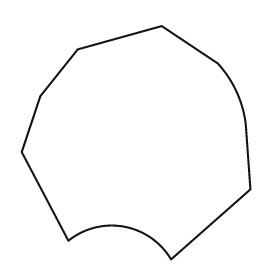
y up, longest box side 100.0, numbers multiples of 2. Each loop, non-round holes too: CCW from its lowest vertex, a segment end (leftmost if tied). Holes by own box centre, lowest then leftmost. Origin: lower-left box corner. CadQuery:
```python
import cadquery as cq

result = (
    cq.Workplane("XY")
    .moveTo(64.0, 0.0)
    .lineTo(98.0, 30.0)
    .lineTo(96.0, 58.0)
    .threePointArc((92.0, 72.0), (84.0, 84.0))
    .lineTo(60.0, 100.0)
    .lineTo(24.0, 90.0)
    .lineTo(8.0, 70.0)
    .lineTo(0.0, 46.0)
    .lineTo(20.0, 8.0)
    .threePointArc((44.0, 14.0), (64.0, 0.0))
    .close()
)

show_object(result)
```